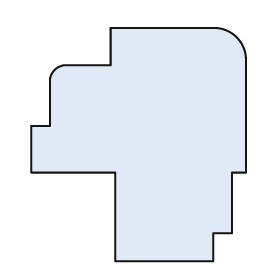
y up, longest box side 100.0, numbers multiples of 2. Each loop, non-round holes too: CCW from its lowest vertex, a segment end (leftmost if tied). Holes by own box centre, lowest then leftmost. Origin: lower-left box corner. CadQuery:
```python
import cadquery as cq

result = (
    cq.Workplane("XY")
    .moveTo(36.0, 0.0)
    .lineTo(78.0, 0.0)
    .lineTo(78.0, 12.0)
    .lineTo(86.0, 12.0)
    .lineTo(86.0, 38.0)
    .lineTo(92.0, 38.0)
    .lineTo(92.0, 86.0)
    .threePointArc((88.0, 96.0), (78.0, 100.0))
    .lineTo(34.0, 100.0)
    .lineTo(34.0, 84.0)
    .lineTo(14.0, 84.0)
    .threePointArc((10.0, 82.0), (8.0, 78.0))
    .lineTo(8.0, 58.0)
    .lineTo(0.0, 58.0)
    .lineTo(0.0, 38.0)
    .lineTo(36.0, 38.0)
    .close()
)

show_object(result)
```